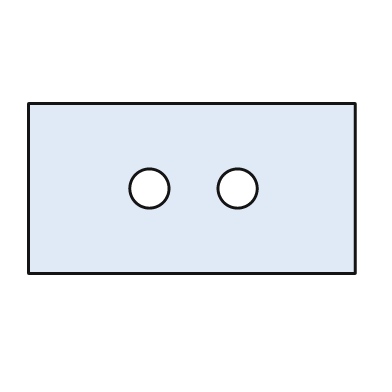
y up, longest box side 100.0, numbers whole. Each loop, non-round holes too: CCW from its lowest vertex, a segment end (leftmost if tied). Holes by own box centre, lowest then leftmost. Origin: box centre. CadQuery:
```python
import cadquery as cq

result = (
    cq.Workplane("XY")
    .moveTo(-50.0, -26.0)
    .lineTo(50.0, -26.0)
    .lineTo(50.0, 26.0)
    .lineTo(-50.0, 26.0)
    .close()
    .moveTo(-13.0, 0.0)
    .circle(6.0)
    .moveTo(14.0, 0.0)
    .circle(6.0)
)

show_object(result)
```